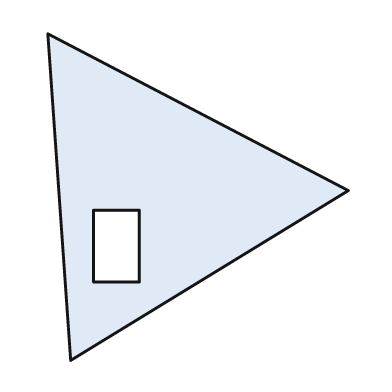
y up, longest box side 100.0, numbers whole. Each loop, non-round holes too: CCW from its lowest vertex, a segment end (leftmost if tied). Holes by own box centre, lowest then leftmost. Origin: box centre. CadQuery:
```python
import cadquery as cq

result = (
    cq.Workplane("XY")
    .moveTo(-39.0, -50.0)
    .lineTo(46.0, 2.0)
    .lineTo(-46.0, 50.0)
    .close()
    .moveTo(-32.0, -26.0)
    .lineTo(-18.0, -26.0)
    .lineTo(-18.0, -4.0)
    .lineTo(-32.0, -4.0)
    .close()
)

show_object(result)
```